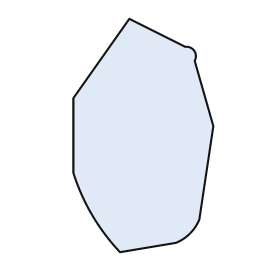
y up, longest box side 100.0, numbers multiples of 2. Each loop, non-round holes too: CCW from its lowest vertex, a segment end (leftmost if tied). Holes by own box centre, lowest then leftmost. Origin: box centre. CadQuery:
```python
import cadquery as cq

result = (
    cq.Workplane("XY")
    .moveTo(-10.0, -50.0)
    .lineTo(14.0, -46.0)
    .threePointArc((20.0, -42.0), (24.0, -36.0))
    .lineTo(30.0, 4.0)
    .lineTo(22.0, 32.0)
    .threePointArc((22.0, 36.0), (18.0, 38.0))
    .lineTo(-6.0, 50.0)
    .lineTo(-30.0, 16.0)
    .lineTo(-30.0, -16.0)
    .threePointArc((-22.0, -34.0), (-10.0, -50.0))
    .close()
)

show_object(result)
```